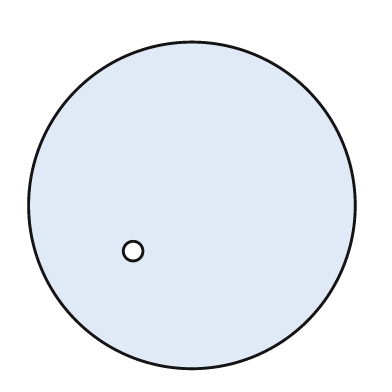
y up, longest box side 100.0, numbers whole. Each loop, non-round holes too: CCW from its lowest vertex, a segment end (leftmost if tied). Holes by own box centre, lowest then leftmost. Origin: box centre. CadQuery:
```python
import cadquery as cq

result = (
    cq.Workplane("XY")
    .moveTo(0.0, 0.0)
    .circle(50.0)
    .moveTo(-18.0, -14.0)
    .circle(3.0)
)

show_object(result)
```